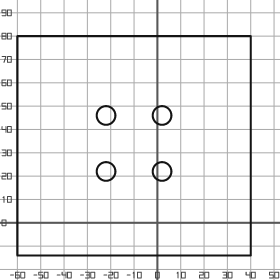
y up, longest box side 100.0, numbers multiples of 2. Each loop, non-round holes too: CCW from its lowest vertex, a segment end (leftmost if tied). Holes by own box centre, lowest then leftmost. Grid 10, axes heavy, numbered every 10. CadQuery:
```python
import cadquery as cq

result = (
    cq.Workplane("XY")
    .moveTo(-60.0, -14.0)
    .lineTo(40.0, -14.0)
    .lineTo(40.0, 80.0)
    .lineTo(-60.0, 80.0)
    .close()
    .moveTo(-22.0, 22.0)
    .circle(4.0)
    .moveTo(2.0, 22.0)
    .circle(4.0)
    .moveTo(-22.0, 46.0)
    .circle(4.0)
    .moveTo(2.0, 46.0)
    .circle(4.0)
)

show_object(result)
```